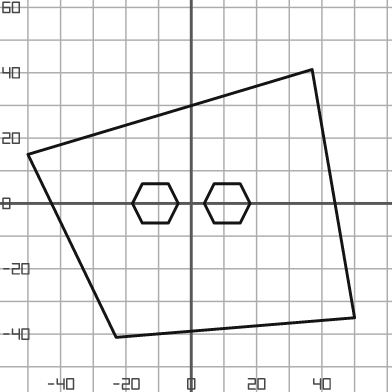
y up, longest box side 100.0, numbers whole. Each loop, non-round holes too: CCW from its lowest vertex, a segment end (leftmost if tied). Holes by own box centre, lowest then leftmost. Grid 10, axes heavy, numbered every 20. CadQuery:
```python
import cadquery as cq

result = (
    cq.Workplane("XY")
    .moveTo(-23.0, -41.0)
    .lineTo(50.0, -35.0)
    .lineTo(37.0, 41.0)
    .lineTo(-50.0, 15.0)
    .close()
    .moveTo(-15.0, -6.0)
    .lineTo(-7.0, -6.0)
    .lineTo(-4.0, 0.0)
    .lineTo(-7.0, 6.0)
    .lineTo(-15.0, 6.0)
    .lineTo(-18.0, 0.0)
    .close()
    .moveTo(7.0, -6.0)
    .lineTo(15.0, -6.0)
    .lineTo(18.0, 0.0)
    .lineTo(15.0, 6.0)
    .lineTo(7.0, 6.0)
    .lineTo(4.0, 0.0)
    .close()
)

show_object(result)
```